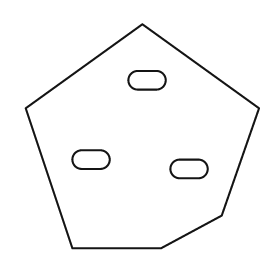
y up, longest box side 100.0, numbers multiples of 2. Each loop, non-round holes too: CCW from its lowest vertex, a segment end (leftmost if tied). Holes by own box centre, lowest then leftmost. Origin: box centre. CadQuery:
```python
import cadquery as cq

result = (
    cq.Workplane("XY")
    .moveTo(-30.0, -48.0)
    .lineTo(8.0, -48.0)
    .lineTo(34.0, -34.0)
    .lineTo(50.0, 12.0)
    .lineTo(0.0, 48.0)
    .lineTo(-50.0, 12.0)
    .close()
    .moveTo(16.0, -18.0)
    .lineTo(24.0, -18.0)
    .threePointArc((28.0, -14.0), (24.0, -10.0))
    .lineTo(16.0, -10.0)
    .threePointArc((12.0, -14.0), (16.0, -18.0))
    .close()
    .moveTo(-26.0, -14.0)
    .lineTo(-18.0, -14.0)
    .threePointArc((-14.0, -10.0), (-18.0, -6.0))
    .lineTo(-26.0, -6.0)
    .threePointArc((-30.0, -10.0), (-26.0, -14.0))
    .close()
    .moveTo(-2.0, 20.0)
    .lineTo(6.0, 20.0)
    .threePointArc((10.0, 24.0), (6.0, 28.0))
    .lineTo(-2.0, 28.0)
    .threePointArc((-6.0, 24.0), (-2.0, 20.0))
    .close()
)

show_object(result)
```